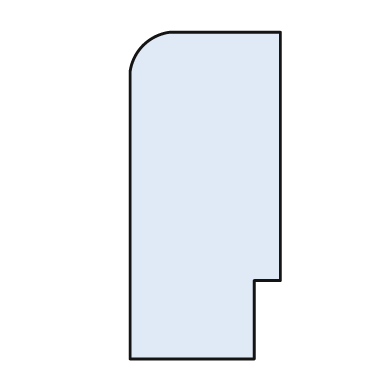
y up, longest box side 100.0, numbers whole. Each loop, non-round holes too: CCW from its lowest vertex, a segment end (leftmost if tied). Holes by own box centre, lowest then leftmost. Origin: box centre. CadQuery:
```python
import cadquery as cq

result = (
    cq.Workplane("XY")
    .moveTo(-23.0, -50.0)
    .lineTo(15.0, -50.0)
    .lineTo(15.0, -26.0)
    .lineTo(23.0, -26.0)
    .lineTo(23.0, 50.0)
    .lineTo(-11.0, 50.0)
    .threePointArc((-19.0, 46.0), (-23.0, 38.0))
    .close()
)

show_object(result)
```